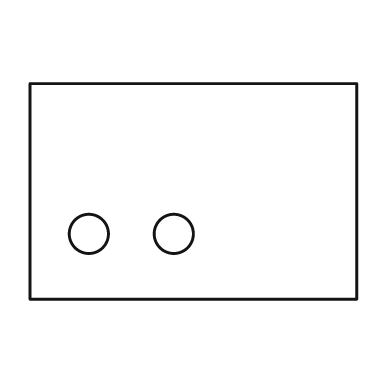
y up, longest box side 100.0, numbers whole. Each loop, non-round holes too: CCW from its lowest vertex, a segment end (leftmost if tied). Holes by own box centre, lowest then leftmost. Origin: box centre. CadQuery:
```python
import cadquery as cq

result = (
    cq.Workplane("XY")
    .moveTo(-50.0, -33.0)
    .lineTo(50.0, -33.0)
    .lineTo(50.0, 33.0)
    .lineTo(-50.0, 33.0)
    .close()
    .moveTo(-32.0, -13.0)
    .circle(6.0)
    .moveTo(-6.0, -13.0)
    .circle(6.0)
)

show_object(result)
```